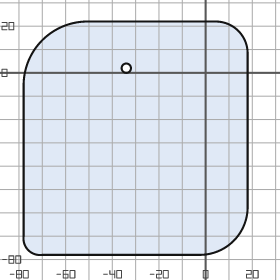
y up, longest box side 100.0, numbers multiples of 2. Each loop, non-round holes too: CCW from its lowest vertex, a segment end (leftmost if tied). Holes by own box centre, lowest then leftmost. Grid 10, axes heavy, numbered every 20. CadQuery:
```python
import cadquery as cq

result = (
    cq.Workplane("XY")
    .moveTo(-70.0, -78.0)
    .lineTo(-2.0, -78.0)
    .threePointArc((12.0, -72.0), (18.0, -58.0))
    .lineTo(18.0, 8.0)
    .threePointArc((14.0, 18.0), (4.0, 22.0))
    .lineTo(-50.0, 22.0)
    .threePointArc((-70.0, 14.0), (-78.0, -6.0))
    .lineTo(-78.0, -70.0)
    .threePointArc((-76.0, -76.0), (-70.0, -78.0))
    .close()
    .moveTo(-34.0, 2.0)
    .circle(2.0)
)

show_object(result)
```